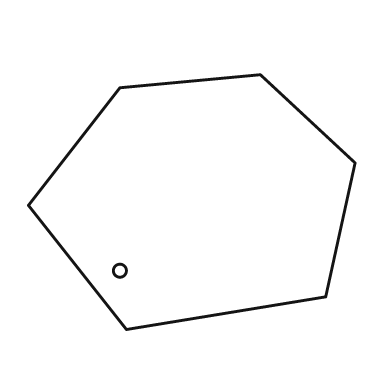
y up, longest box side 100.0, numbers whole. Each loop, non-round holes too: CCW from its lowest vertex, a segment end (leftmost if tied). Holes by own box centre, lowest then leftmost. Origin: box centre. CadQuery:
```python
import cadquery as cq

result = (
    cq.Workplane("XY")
    .moveTo(-20.0, -39.0)
    .lineTo(41.0, -29.0)
    .lineTo(50.0, 12.0)
    .lineTo(21.0, 39.0)
    .lineTo(-22.0, 35.0)
    .lineTo(-50.0, -1.0)
    .close()
    .moveTo(-22.0, -21.0)
    .circle(2.0)
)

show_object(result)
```